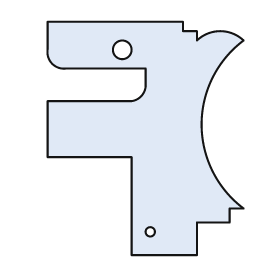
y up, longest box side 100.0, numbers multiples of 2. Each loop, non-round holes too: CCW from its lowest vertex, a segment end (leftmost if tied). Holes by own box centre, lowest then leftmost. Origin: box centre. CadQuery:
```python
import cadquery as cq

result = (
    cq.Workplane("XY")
    .moveTo(-6.0, -50.0)
    .lineTo(22.0, -50.0)
    .lineTo(22.0, -36.0)
    .lineTo(36.0, -36.0)
    .lineTo(36.0, -30.0)
    .lineTo(42.0, -30.0)
    .threePointArc((24.0, 6.0), (42.0, 42.0))
    .threePointArc((32.0, 46.0), (22.0, 42.0))
    .lineTo(22.0, 46.0)
    .lineTo(16.0, 46.0)
    .lineTo(16.0, 50.0)
    .lineTo(-42.0, 50.0)
    .lineTo(-42.0, 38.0)
    .threePointArc((-40.0, 32.0), (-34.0, 30.0))
    .lineTo(0.0, 30.0)
    .lineTo(0.0, 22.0)
    .threePointArc((-2.0, 18.0), (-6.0, 16.0))
    .lineTo(-42.0, 16.0)
    .lineTo(-42.0, -8.0)
    .lineTo(-6.0, -8.0)
    .close()
    .moveTo(2.0, -40.0)
    .circle(2.0)
    .moveTo(-10.0, 38.0)
    .circle(4.0)
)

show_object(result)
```